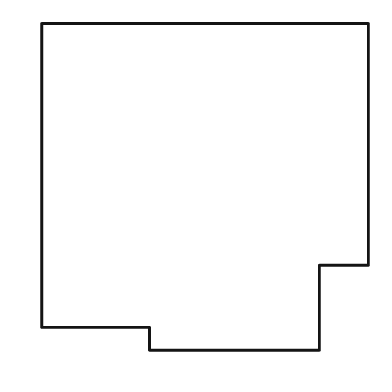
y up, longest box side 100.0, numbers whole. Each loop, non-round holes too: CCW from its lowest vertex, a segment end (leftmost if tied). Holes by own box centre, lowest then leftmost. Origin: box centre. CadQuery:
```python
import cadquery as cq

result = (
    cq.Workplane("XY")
    .moveTo(-17.0, -50.0)
    .lineTo(35.0, -50.0)
    .lineTo(35.0, -24.0)
    .lineTo(50.0, -24.0)
    .lineTo(50.0, 50.0)
    .lineTo(-50.0, 50.0)
    .lineTo(-50.0, -43.0)
    .lineTo(-17.0, -43.0)
    .close()
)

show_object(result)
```